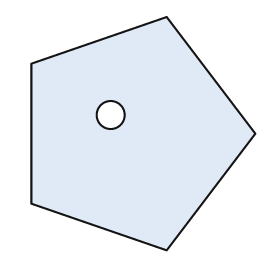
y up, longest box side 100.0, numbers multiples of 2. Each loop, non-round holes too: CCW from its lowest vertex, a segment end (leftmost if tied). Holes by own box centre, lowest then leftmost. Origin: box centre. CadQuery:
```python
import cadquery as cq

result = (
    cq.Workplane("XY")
    .moveTo(10.0, -50.0)
    .lineTo(48.0, 0.0)
    .lineTo(10.0, 50.0)
    .lineTo(-48.0, 30.0)
    .lineTo(-48.0, -30.0)
    .close()
    .moveTo(-14.0, 8.0)
    .circle(6.0)
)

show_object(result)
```